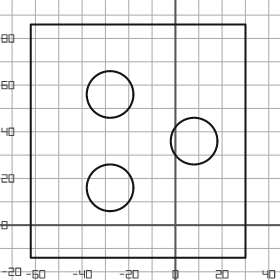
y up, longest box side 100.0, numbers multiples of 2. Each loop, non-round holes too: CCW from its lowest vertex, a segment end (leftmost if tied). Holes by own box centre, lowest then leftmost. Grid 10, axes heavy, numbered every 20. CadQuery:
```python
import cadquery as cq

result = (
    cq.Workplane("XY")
    .moveTo(-62.0, -14.0)
    .lineTo(30.0, -14.0)
    .lineTo(30.0, 86.0)
    .lineTo(-62.0, 86.0)
    .close()
    .moveTo(-28.0, 16.0)
    .circle(10.0)
    .moveTo(8.0, 36.0)
    .circle(10.0)
    .moveTo(-28.0, 56.0)
    .circle(10.0)
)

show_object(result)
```